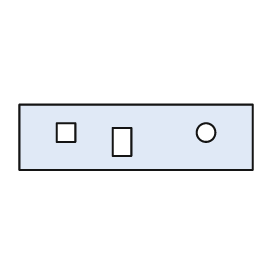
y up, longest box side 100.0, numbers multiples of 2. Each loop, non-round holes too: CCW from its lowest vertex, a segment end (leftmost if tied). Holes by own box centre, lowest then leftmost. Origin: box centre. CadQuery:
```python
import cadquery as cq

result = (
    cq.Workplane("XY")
    .moveTo(-50.0, -14.0)
    .lineTo(50.0, -14.0)
    .lineTo(50.0, 14.0)
    .lineTo(-50.0, 14.0)
    .close()
    .moveTo(-10.0, -8.0)
    .lineTo(-2.0, -8.0)
    .lineTo(-2.0, 4.0)
    .lineTo(-10.0, 4.0)
    .close()
    .moveTo(-34.0, -2.0)
    .lineTo(-26.0, -2.0)
    .lineTo(-26.0, 6.0)
    .lineTo(-34.0, 6.0)
    .close()
    .moveTo(30.0, 2.0)
    .circle(4.0)
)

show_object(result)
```